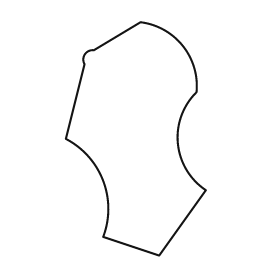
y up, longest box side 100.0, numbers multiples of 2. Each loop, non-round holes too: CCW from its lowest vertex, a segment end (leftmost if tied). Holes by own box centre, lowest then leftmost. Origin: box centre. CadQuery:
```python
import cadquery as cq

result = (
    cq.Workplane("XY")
    .moveTo(10.0, -50.0)
    .lineTo(30.0, -22.0)
    .threePointArc((18.0, -2.0), (26.0, 20.0))
    .threePointArc((20.0, 40.0), (2.0, 50.0))
    .lineTo(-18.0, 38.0)
    .threePointArc((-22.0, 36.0), (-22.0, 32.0))
    .lineTo(-30.0, 0.0)
    .threePointArc((-14.0, -18.0), (-14.0, -42.0))
    .close()
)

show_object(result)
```